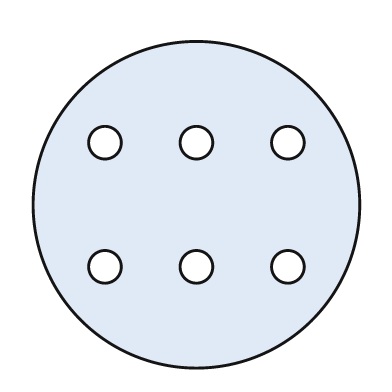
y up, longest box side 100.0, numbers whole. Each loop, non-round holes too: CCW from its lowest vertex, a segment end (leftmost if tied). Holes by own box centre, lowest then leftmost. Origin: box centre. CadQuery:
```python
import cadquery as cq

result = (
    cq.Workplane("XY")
    .moveTo(0.0, 0.0)
    .circle(50.0)
    .moveTo(-28.0, -19.0)
    .circle(5.0)
    .moveTo(0.0, -19.0)
    .circle(5.0)
    .moveTo(28.0, -19.0)
    .circle(5.0)
    .moveTo(-28.0, 19.0)
    .circle(5.0)
    .moveTo(0.0, 19.0)
    .circle(5.0)
    .moveTo(28.0, 19.0)
    .circle(5.0)
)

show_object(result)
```